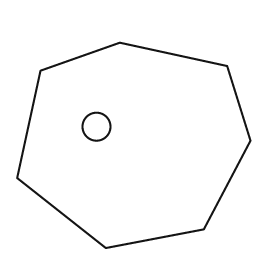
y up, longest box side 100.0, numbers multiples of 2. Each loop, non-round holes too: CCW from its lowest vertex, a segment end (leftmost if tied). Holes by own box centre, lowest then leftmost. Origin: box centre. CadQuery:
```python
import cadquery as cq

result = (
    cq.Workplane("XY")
    .moveTo(-12.0, -44.0)
    .lineTo(30.0, -36.0)
    .lineTo(50.0, 2.0)
    .lineTo(40.0, 34.0)
    .lineTo(-6.0, 44.0)
    .lineTo(-40.0, 32.0)
    .lineTo(-50.0, -14.0)
    .close()
    .moveTo(-16.0, 8.0)
    .circle(6.0)
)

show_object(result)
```